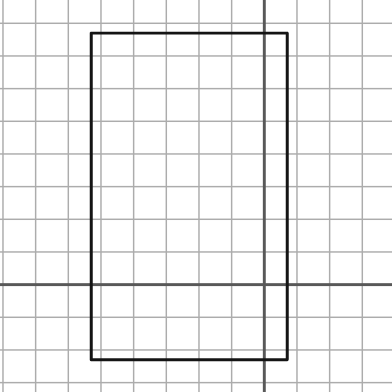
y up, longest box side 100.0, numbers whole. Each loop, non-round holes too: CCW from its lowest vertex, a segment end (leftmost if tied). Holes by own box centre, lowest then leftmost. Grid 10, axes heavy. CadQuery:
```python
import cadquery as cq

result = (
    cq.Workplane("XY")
    .moveTo(-53.0, -23.0)
    .lineTo(7.0, -23.0)
    .lineTo(7.0, 77.0)
    .lineTo(-53.0, 77.0)
    .close()
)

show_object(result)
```